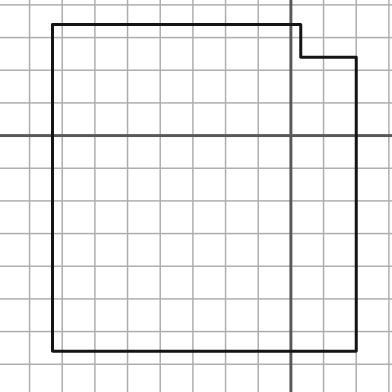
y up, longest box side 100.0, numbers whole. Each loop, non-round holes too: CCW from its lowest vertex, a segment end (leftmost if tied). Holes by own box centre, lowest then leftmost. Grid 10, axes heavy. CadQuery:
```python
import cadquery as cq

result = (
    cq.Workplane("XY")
    .moveTo(-73.0, -66.0)
    .lineTo(20.0, -66.0)
    .lineTo(20.0, 24.0)
    .lineTo(3.0, 24.0)
    .lineTo(3.0, 34.0)
    .lineTo(-73.0, 34.0)
    .close()
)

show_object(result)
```